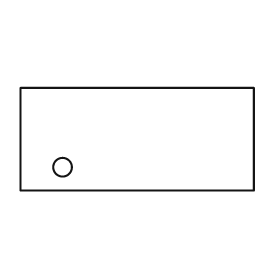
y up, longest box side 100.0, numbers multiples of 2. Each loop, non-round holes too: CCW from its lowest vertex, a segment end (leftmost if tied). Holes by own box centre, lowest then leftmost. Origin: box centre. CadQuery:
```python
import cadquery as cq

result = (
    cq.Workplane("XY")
    .moveTo(-50.0, -22.0)
    .lineTo(50.0, -22.0)
    .lineTo(50.0, 22.0)
    .lineTo(-50.0, 22.0)
    .close()
    .moveTo(-32.0, -12.0)
    .circle(4.0)
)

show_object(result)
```